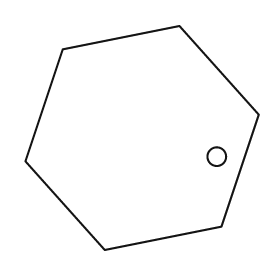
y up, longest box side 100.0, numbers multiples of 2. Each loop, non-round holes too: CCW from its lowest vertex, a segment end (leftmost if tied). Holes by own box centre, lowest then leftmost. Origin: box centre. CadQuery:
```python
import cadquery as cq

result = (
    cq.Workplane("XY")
    .moveTo(-16.0, -48.0)
    .lineTo(34.0, -38.0)
    .lineTo(50.0, 10.0)
    .lineTo(16.0, 48.0)
    .lineTo(-34.0, 38.0)
    .lineTo(-50.0, -10.0)
    .close()
    .moveTo(32.0, -8.0)
    .circle(4.0)
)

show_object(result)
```